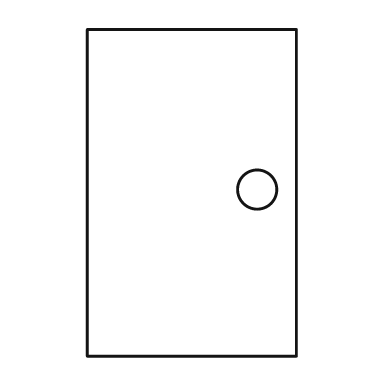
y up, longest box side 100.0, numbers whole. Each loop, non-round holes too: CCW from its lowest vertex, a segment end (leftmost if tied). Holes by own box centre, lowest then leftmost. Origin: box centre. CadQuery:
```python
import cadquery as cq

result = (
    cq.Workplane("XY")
    .moveTo(-32.0, -50.0)
    .lineTo(32.0, -50.0)
    .lineTo(32.0, 50.0)
    .lineTo(-32.0, 50.0)
    .close()
    .moveTo(20.0, 1.0)
    .circle(6.0)
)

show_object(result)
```